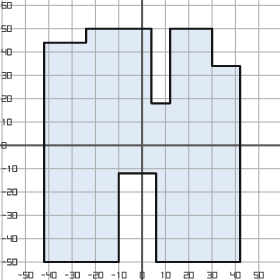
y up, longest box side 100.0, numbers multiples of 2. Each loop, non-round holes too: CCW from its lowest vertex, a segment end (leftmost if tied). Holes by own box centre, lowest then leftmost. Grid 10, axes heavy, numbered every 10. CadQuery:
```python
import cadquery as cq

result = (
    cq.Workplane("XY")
    .moveTo(-42.0, -50.0)
    .lineTo(-10.0, -50.0)
    .lineTo(-10.0, -12.0)
    .lineTo(6.0, -12.0)
    .lineTo(6.0, -50.0)
    .lineTo(42.0, -50.0)
    .lineTo(42.0, 34.0)
    .lineTo(30.0, 34.0)
    .lineTo(30.0, 50.0)
    .lineTo(12.0, 50.0)
    .lineTo(12.0, 18.0)
    .lineTo(4.0, 18.0)
    .lineTo(4.0, 50.0)
    .lineTo(-24.0, 50.0)
    .lineTo(-24.0, 44.0)
    .lineTo(-42.0, 44.0)
    .close()
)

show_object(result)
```